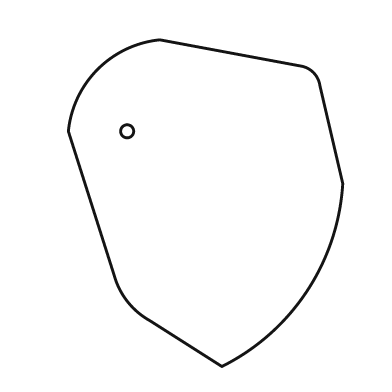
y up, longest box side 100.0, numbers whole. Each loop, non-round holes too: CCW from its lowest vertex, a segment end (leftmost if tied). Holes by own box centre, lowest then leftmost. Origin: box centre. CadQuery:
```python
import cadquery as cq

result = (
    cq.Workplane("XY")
    .moveTo(5.0, -50.0)
    .threePointArc((31.0, -27.0), (42.0, 6.0))
    .lineTo(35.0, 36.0)
    .threePointArc((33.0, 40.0), (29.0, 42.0))
    .lineTo(-14.0, 50.0)
    .threePointArc((-33.0, 41.0), (-42.0, 22.0))
    .lineTo(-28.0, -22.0)
    .threePointArc((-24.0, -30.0), (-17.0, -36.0))
    .close()
    .moveTo(-24.0, 22.0)
    .circle(2.0)
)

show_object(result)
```